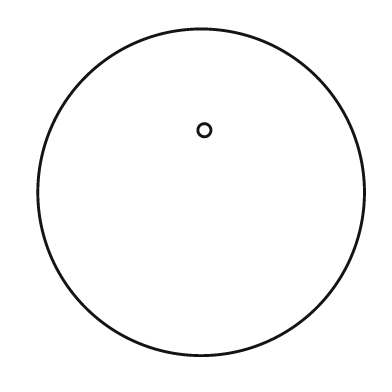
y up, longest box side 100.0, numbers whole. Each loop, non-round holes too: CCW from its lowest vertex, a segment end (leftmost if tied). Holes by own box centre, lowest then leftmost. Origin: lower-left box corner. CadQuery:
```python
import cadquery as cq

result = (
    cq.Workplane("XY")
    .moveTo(50.0, 50.0)
    .circle(50.0)
    .moveTo(51.0, 69.0)
    .circle(2.0)
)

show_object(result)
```